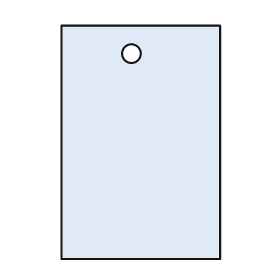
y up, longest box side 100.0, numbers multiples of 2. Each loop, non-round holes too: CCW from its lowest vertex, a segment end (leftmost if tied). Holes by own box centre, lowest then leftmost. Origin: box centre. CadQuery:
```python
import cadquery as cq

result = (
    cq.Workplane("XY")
    .moveTo(-34.0, -50.0)
    .lineTo(34.0, -50.0)
    .lineTo(34.0, 50.0)
    .lineTo(-34.0, 50.0)
    .close()
    .moveTo(-4.0, 38.0)
    .circle(4.0)
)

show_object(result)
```